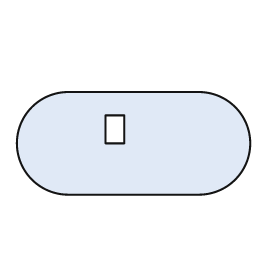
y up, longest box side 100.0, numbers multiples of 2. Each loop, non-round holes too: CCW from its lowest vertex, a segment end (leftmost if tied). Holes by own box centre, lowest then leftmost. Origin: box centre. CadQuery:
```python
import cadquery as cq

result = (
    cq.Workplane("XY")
    .moveTo(-28.0, -22.0)
    .lineTo(28.0, -22.0)
    .threePointArc((50.0, 0.0), (28.0, 22.0))
    .lineTo(-28.0, 22.0)
    .threePointArc((-50.0, 0.0), (-28.0, -22.0))
    .close()
    .moveTo(-12.0, 0.0)
    .lineTo(-4.0, 0.0)
    .lineTo(-4.0, 12.0)
    .lineTo(-12.0, 12.0)
    .close()
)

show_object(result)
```